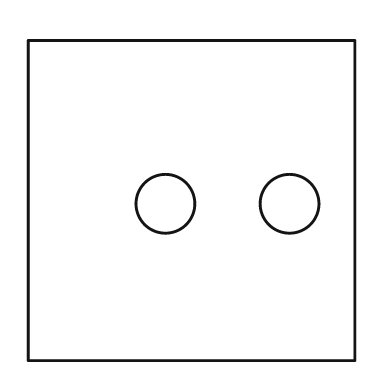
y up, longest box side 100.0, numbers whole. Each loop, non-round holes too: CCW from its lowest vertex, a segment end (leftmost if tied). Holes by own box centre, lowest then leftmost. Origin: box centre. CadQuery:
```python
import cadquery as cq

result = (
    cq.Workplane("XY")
    .moveTo(-50.0, -49.0)
    .lineTo(50.0, -49.0)
    .lineTo(50.0, 49.0)
    .lineTo(-50.0, 49.0)
    .close()
    .moveTo(-8.0, -1.0)
    .circle(9.0)
    .moveTo(30.0, -1.0)
    .circle(9.0)
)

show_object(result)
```